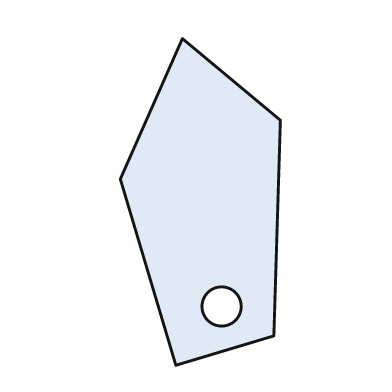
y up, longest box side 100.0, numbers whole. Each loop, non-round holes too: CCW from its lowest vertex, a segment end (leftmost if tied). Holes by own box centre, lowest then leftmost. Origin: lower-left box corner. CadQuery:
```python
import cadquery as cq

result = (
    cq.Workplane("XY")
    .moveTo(17.0, 0.0)
    .lineTo(47.0, 9.0)
    .lineTo(49.0, 75.0)
    .lineTo(19.0, 100.0)
    .lineTo(0.0, 57.0)
    .close()
    .moveTo(31.0, 18.0)
    .circle(6.0)
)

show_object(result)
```